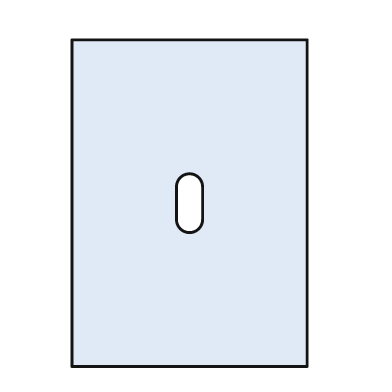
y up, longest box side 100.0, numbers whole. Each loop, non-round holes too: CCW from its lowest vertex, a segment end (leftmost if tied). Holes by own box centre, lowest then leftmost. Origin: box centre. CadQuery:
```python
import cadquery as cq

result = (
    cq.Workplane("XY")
    .moveTo(-36.0, -50.0)
    .lineTo(36.0, -50.0)
    .lineTo(36.0, 50.0)
    .lineTo(-36.0, 50.0)
    .close()
    .moveTo(-4.0, -5.0)
    .threePointArc((0.0, -9.0), (4.0, -5.0))
    .lineTo(4.0, 5.0)
    .threePointArc((0.0, 9.0), (-4.0, 5.0))
    .close()
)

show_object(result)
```